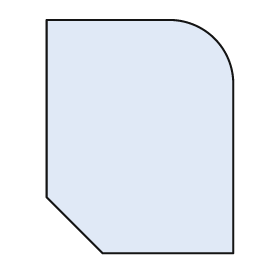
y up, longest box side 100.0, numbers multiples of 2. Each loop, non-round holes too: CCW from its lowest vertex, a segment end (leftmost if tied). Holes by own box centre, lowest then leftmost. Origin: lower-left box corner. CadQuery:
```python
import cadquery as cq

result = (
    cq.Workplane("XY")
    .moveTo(24.0, 0.0)
    .lineTo(80.0, 0.0)
    .lineTo(80.0, 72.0)
    .threePointArc((72.0, 92.0), (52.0, 100.0))
    .lineTo(0.0, 100.0)
    .lineTo(0.0, 24.0)
    .close()
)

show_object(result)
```